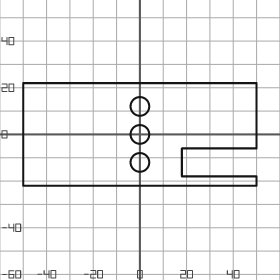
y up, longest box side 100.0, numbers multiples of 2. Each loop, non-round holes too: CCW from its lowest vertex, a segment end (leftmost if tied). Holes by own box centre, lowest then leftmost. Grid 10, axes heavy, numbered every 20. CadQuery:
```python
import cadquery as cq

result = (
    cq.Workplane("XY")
    .moveTo(-50.0, -22.0)
    .lineTo(50.0, -22.0)
    .lineTo(50.0, -18.0)
    .lineTo(18.0, -18.0)
    .lineTo(18.0, -6.0)
    .lineTo(50.0, -6.0)
    .lineTo(50.0, 22.0)
    .lineTo(-50.0, 22.0)
    .close()
    .moveTo(0.0, -12.0)
    .circle(4.0)
    .moveTo(0.0, 0.0)
    .circle(4.0)
    .moveTo(0.0, 12.0)
    .circle(4.0)
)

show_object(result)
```